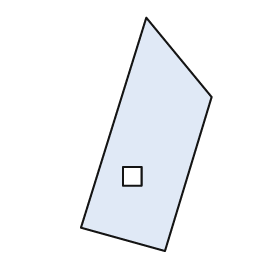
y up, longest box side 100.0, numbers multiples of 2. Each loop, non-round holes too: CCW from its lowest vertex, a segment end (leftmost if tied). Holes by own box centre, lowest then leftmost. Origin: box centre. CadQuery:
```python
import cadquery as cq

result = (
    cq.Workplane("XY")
    .moveTo(8.0, -50.0)
    .lineTo(28.0, 16.0)
    .lineTo(0.0, 50.0)
    .lineTo(-28.0, -40.0)
    .close()
    .moveTo(-10.0, -22.0)
    .lineTo(-2.0, -22.0)
    .lineTo(-2.0, -14.0)
    .lineTo(-10.0, -14.0)
    .close()
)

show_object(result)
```